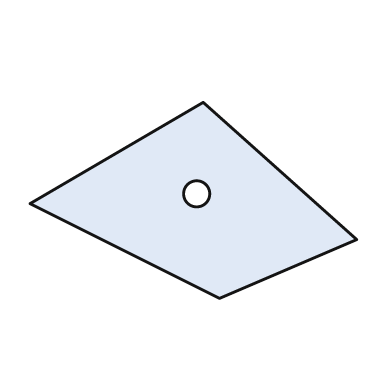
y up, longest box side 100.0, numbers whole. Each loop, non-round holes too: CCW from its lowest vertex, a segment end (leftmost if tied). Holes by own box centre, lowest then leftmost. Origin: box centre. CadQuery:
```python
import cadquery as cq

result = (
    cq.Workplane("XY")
    .moveTo(8.0, -30.0)
    .lineTo(50.0, -12.0)
    .lineTo(3.0, 30.0)
    .lineTo(-50.0, -1.0)
    .close()
    .moveTo(1.0, 2.0)
    .circle(4.0)
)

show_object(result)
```